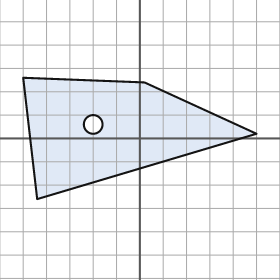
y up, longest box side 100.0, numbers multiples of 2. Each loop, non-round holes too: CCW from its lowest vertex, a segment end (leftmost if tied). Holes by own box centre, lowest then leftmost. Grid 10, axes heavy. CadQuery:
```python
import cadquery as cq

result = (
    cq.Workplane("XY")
    .moveTo(-44.0, -26.0)
    .lineTo(50.0, 2.0)
    .lineTo(2.0, 24.0)
    .lineTo(-50.0, 26.0)
    .close()
    .moveTo(-20.0, 6.0)
    .circle(4.0)
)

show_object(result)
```